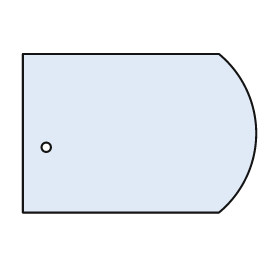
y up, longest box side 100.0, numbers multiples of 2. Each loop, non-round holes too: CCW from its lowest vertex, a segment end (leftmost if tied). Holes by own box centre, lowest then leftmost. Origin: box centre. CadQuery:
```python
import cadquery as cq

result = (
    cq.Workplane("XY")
    .moveTo(-50.0, -34.0)
    .lineTo(34.0, -34.0)
    .threePointArc((50.0, 0.0), (34.0, 34.0))
    .lineTo(-50.0, 34.0)
    .close()
    .moveTo(-40.0, -6.0)
    .circle(2.0)
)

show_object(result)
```